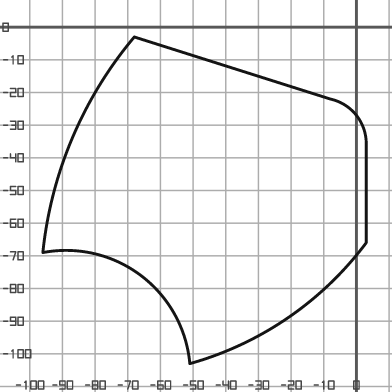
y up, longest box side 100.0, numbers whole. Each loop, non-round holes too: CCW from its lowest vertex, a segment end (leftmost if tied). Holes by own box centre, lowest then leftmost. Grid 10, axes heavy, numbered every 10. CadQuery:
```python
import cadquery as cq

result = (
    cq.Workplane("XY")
    .moveTo(-51.0, -103.0)
    .threePointArc((-21.0, -89.0), (3.0, -66.0))
    .lineTo(3.0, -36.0)
    .threePointArc((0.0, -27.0), (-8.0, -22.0))
    .lineTo(-68.0, -3.0)
    .threePointArc((-87.0, -34.0), (-96.0, -69.0))
    .threePointArc((-66.0, -76.0), (-51.0, -103.0))
    .close()
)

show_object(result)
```